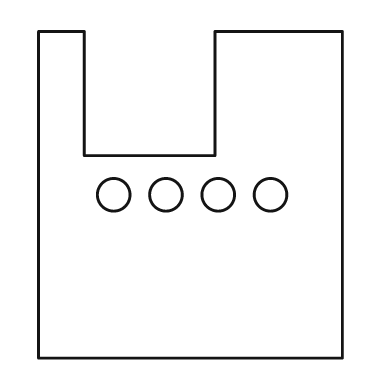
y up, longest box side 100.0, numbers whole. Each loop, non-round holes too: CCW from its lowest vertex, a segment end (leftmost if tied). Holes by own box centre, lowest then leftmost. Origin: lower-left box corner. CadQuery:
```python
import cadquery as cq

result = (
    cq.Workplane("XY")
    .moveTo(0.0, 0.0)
    .lineTo(93.0, 0.0)
    .lineTo(93.0, 100.0)
    .lineTo(54.0, 100.0)
    .lineTo(54.0, 62.0)
    .lineTo(14.0, 62.0)
    .lineTo(14.0, 100.0)
    .lineTo(0.0, 100.0)
    .close()
    .moveTo(23.0, 50.0)
    .circle(5.0)
    .moveTo(39.0, 50.0)
    .circle(5.0)
    .moveTo(55.0, 50.0)
    .circle(5.0)
    .moveTo(71.0, 50.0)
    .circle(5.0)
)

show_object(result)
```